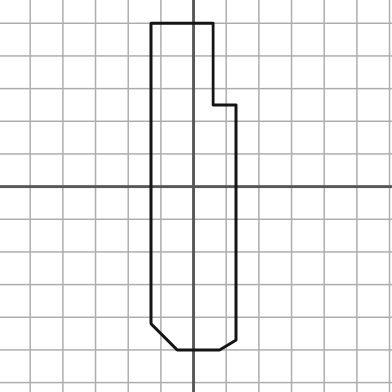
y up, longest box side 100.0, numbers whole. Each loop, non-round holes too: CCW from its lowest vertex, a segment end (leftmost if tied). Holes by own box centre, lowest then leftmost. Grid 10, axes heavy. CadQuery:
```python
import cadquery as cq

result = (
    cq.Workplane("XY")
    .moveTo(-5.0, -50.0)
    .lineTo(8.0, -50.0)
    .lineTo(13.0, -47.0)
    .lineTo(13.0, 25.0)
    .lineTo(6.0, 25.0)
    .lineTo(6.0, 50.0)
    .lineTo(-13.0, 50.0)
    .lineTo(-13.0, -42.0)
    .close()
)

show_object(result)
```